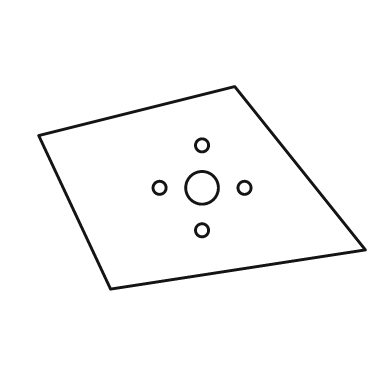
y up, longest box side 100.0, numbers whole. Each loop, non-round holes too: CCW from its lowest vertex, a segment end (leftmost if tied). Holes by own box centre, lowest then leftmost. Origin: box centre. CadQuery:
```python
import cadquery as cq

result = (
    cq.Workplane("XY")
    .moveTo(-28.0, -31.0)
    .lineTo(50.0, -19.0)
    .lineTo(10.0, 31.0)
    .lineTo(-50.0, 16.0)
    .close()
    .moveTo(0.0, -13.0)
    .circle(2.0)
    .moveTo(-13.0, 0.0)
    .circle(2.0)
    .moveTo(0.0, 0.0)
    .circle(5.0)
    .moveTo(13.0, 0.0)
    .circle(2.0)
    .moveTo(0.0, 13.0)
    .circle(2.0)
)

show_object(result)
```